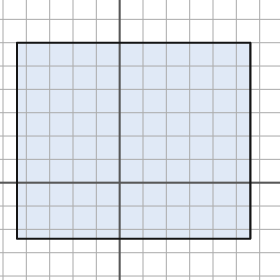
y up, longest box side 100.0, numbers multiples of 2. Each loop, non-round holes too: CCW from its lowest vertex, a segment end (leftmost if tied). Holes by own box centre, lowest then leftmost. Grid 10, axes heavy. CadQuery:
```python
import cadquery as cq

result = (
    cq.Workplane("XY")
    .moveTo(-44.0, -24.0)
    .lineTo(56.0, -24.0)
    .lineTo(56.0, 60.0)
    .lineTo(-44.0, 60.0)
    .close()
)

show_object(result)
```